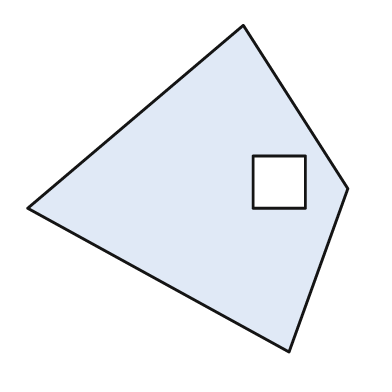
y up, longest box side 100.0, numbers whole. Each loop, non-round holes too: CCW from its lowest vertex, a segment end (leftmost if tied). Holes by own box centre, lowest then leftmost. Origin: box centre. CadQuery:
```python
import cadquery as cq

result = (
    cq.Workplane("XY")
    .moveTo(31.0, -50.0)
    .lineTo(49.0, 0.0)
    .lineTo(17.0, 50.0)
    .lineTo(-49.0, -6.0)
    .close()
    .moveTo(20.0, -6.0)
    .lineTo(36.0, -6.0)
    .lineTo(36.0, 10.0)
    .lineTo(20.0, 10.0)
    .close()
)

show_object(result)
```